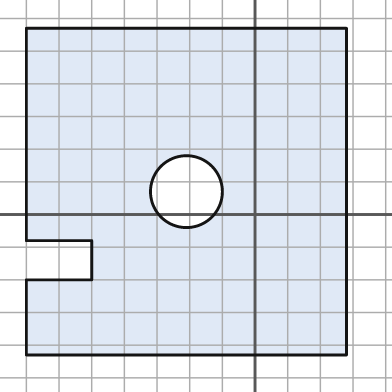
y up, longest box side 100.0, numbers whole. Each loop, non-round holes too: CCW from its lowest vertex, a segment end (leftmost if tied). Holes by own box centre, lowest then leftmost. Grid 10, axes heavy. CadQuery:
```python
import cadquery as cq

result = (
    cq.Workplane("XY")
    .moveTo(-70.0, -43.0)
    .lineTo(28.0, -43.0)
    .lineTo(28.0, 57.0)
    .lineTo(-70.0, 57.0)
    .lineTo(-70.0, -8.0)
    .lineTo(-50.0, -8.0)
    .lineTo(-50.0, -20.0)
    .lineTo(-70.0, -20.0)
    .close()
    .moveTo(-21.0, 7.0)
    .circle(11.0)
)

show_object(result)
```